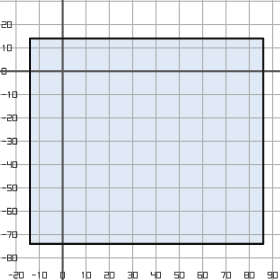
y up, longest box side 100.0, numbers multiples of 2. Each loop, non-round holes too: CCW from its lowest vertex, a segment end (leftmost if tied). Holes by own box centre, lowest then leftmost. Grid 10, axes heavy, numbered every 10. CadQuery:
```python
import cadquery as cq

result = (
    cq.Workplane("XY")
    .moveTo(-14.0, -74.0)
    .lineTo(86.0, -74.0)
    .lineTo(86.0, 14.0)
    .lineTo(-14.0, 14.0)
    .close()
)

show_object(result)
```